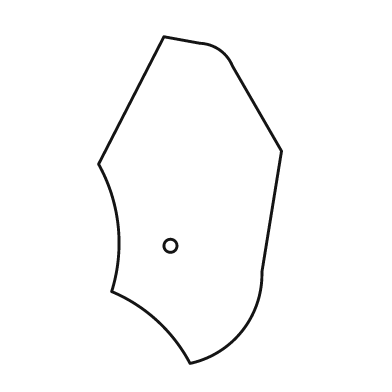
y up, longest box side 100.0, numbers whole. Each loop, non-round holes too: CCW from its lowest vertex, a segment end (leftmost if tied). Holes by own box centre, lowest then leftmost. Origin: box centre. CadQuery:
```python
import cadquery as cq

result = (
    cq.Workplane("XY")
    .moveTo(0.0, -50.0)
    .threePointArc((16.0, -40.0), (22.0, -22.0))
    .lineTo(28.0, 15.0)
    .lineTo(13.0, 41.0)
    .threePointArc((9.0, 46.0), (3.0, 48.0))
    .lineTo(-8.0, 50.0)
    .lineTo(-28.0, 11.0)
    .threePointArc((-22.0, -8.0), (-24.0, -28.0))
    .threePointArc((-10.0, -37.0), (0.0, -50.0))
    .close()
    .moveTo(-6.0, -14.0)
    .circle(2.0)
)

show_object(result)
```